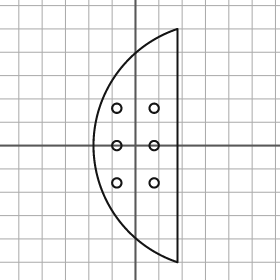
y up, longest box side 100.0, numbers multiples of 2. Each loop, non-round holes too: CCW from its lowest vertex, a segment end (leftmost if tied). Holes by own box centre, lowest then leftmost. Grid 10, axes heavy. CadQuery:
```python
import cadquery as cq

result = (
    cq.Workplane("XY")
    .moveTo(18.0, -50.0)
    .lineTo(18.0, 50.0)
    .threePointArc((-18.0, 0.0), (18.0, -50.0))
    .close()
    .moveTo(-8.0, -16.0)
    .circle(2.0)
    .moveTo(8.0, -16.0)
    .circle(2.0)
    .moveTo(-8.0, 0.0)
    .circle(2.0)
    .moveTo(8.0, 0.0)
    .circle(2.0)
    .moveTo(-8.0, 16.0)
    .circle(2.0)
    .moveTo(8.0, 16.0)
    .circle(2.0)
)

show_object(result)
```